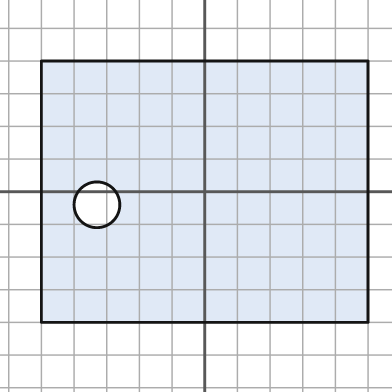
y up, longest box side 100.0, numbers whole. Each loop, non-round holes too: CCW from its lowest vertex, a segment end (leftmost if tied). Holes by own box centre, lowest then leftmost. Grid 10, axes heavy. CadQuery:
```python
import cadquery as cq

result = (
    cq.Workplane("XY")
    .moveTo(-50.0, -40.0)
    .lineTo(50.0, -40.0)
    .lineTo(50.0, 40.0)
    .lineTo(-50.0, 40.0)
    .close()
    .moveTo(-33.0, -4.0)
    .circle(7.0)
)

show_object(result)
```